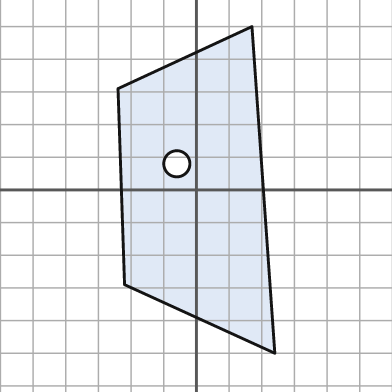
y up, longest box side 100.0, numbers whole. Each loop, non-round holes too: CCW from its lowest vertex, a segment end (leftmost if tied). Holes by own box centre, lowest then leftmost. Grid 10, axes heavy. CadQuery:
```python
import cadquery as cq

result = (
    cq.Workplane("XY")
    .moveTo(24.0, -50.0)
    .lineTo(17.0, 50.0)
    .lineTo(-24.0, 31.0)
    .lineTo(-22.0, -29.0)
    .close()
    .moveTo(-6.0, 8.0)
    .circle(4.0)
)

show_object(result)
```